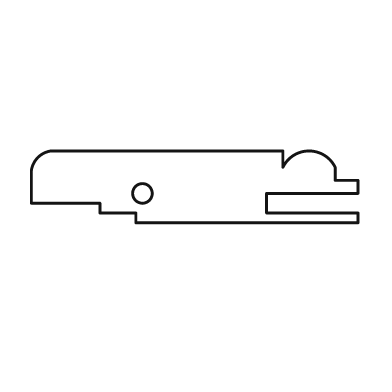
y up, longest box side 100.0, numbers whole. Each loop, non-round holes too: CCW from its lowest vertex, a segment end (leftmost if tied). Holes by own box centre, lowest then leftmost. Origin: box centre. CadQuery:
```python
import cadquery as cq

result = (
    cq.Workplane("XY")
    .moveTo(-18.0, -11.0)
    .lineTo(50.0, -11.0)
    .lineTo(50.0, -8.0)
    .lineTo(22.0, -8.0)
    .lineTo(22.0, -2.0)
    .lineTo(50.0, -2.0)
    .lineTo(50.0, 2.0)
    .lineTo(43.0, 2.0)
    .lineTo(43.0, 6.0)
    .threePointArc((35.0, 11.0), (27.0, 6.0))
    .lineTo(27.0, 11.0)
    .lineTo(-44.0, 11.0)
    .threePointArc((-48.0, 9.0), (-50.0, 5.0))
    .lineTo(-50.0, -5.0)
    .lineTo(-29.0, -5.0)
    .lineTo(-29.0, -8.0)
    .lineTo(-18.0, -8.0)
    .close()
    .moveTo(-16.0, -2.0)
    .circle(3.0)
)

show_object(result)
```